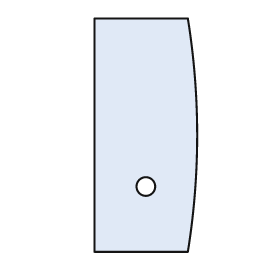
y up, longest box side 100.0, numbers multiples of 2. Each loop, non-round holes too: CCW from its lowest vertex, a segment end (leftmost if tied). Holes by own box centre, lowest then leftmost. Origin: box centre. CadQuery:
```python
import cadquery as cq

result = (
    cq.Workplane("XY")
    .moveTo(-22.0, -50.0)
    .lineTo(18.0, -50.0)
    .threePointArc((22.0, 0.0), (18.0, 50.0))
    .lineTo(-22.0, 50.0)
    .close()
    .moveTo(0.0, -22.0)
    .circle(4.0)
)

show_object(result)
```